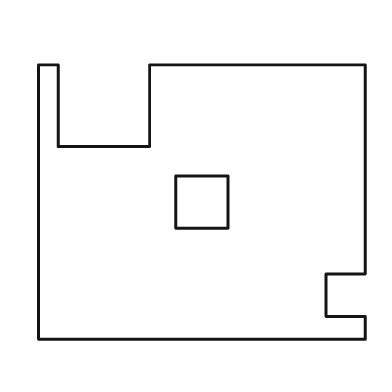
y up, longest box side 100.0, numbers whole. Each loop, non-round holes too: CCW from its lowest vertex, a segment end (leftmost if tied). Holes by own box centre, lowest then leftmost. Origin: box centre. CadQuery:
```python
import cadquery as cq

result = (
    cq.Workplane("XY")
    .moveTo(-50.0, -42.0)
    .lineTo(50.0, -42.0)
    .lineTo(50.0, -35.0)
    .lineTo(38.0, -35.0)
    .lineTo(38.0, -22.0)
    .lineTo(50.0, -22.0)
    .lineTo(50.0, 42.0)
    .lineTo(-16.0, 42.0)
    .lineTo(-16.0, 17.0)
    .lineTo(-44.0, 17.0)
    .lineTo(-44.0, 42.0)
    .lineTo(-50.0, 42.0)
    .close()
    .moveTo(-8.0, -8.0)
    .lineTo(8.0, -8.0)
    .lineTo(8.0, 8.0)
    .lineTo(-8.0, 8.0)
    .close()
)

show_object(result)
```